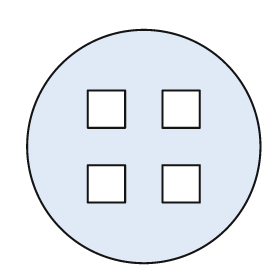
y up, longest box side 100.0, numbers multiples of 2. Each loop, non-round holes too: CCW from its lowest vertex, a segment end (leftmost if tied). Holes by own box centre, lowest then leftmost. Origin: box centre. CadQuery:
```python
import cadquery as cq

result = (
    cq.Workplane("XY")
    .moveTo(0.0, 0.0)
    .circle(50.0)
    .moveTo(-24.0, -24.0)
    .lineTo(-8.0, -24.0)
    .lineTo(-8.0, -8.0)
    .lineTo(-24.0, -8.0)
    .close()
    .moveTo(8.0, -24.0)
    .lineTo(24.0, -24.0)
    .lineTo(24.0, -8.0)
    .lineTo(8.0, -8.0)
    .close()
    .moveTo(-24.0, 8.0)
    .lineTo(-8.0, 8.0)
    .lineTo(-8.0, 24.0)
    .lineTo(-24.0, 24.0)
    .close()
    .moveTo(8.0, 8.0)
    .lineTo(24.0, 8.0)
    .lineTo(24.0, 24.0)
    .lineTo(8.0, 24.0)
    .close()
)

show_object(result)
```